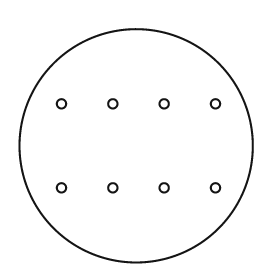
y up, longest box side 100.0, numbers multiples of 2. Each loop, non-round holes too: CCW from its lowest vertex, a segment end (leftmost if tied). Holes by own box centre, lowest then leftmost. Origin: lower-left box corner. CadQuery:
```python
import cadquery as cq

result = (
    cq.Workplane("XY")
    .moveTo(50.0, 50.0)
    .circle(50.0)
    .moveTo(18.0, 32.0)
    .circle(2.0)
    .moveTo(40.0, 32.0)
    .circle(2.0)
    .moveTo(62.0, 32.0)
    .circle(2.0)
    .moveTo(84.0, 32.0)
    .circle(2.0)
    .moveTo(18.0, 68.0)
    .circle(2.0)
    .moveTo(40.0, 68.0)
    .circle(2.0)
    .moveTo(62.0, 68.0)
    .circle(2.0)
    .moveTo(84.0, 68.0)
    .circle(2.0)
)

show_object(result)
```